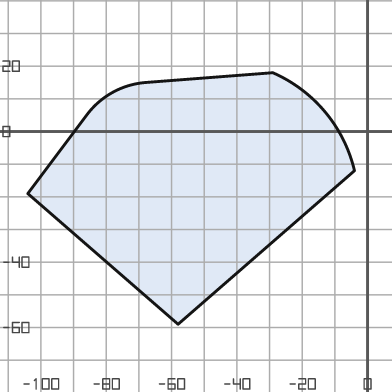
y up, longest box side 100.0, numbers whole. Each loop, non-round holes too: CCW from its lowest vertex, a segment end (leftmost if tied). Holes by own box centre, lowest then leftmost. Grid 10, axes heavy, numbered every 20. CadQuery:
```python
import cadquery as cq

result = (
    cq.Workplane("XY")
    .moveTo(-58.0, -59.0)
    .lineTo(-4.0, -12.0)
    .threePointArc((-13.0, 6.0), (-29.0, 18.0))
    .lineTo(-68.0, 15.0)
    .threePointArc((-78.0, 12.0), (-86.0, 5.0))
    .lineTo(-104.0, -19.0)
    .close()
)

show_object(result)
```